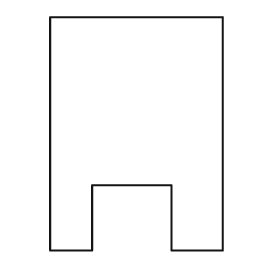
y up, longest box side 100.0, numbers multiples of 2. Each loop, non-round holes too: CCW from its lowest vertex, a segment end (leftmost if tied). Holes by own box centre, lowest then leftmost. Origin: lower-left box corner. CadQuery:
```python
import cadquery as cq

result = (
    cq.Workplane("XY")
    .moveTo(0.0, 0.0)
    .lineTo(18.0, 0.0)
    .lineTo(18.0, 28.0)
    .lineTo(52.0, 28.0)
    .lineTo(52.0, 0.0)
    .lineTo(74.0, 0.0)
    .lineTo(74.0, 100.0)
    .lineTo(0.0, 100.0)
    .close()
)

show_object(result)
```